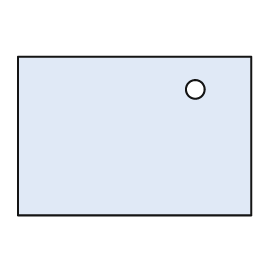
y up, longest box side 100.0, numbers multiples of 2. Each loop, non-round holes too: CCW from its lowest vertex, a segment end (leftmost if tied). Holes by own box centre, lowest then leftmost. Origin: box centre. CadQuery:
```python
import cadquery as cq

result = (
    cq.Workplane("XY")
    .moveTo(-50.0, -34.0)
    .lineTo(50.0, -34.0)
    .lineTo(50.0, 34.0)
    .lineTo(-50.0, 34.0)
    .close()
    .moveTo(26.0, 20.0)
    .circle(4.0)
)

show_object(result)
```